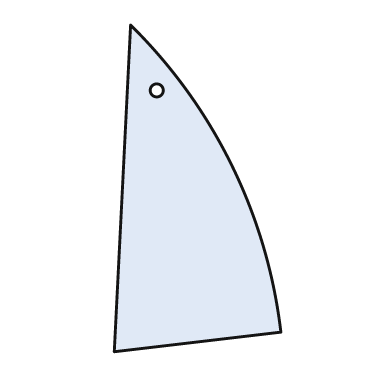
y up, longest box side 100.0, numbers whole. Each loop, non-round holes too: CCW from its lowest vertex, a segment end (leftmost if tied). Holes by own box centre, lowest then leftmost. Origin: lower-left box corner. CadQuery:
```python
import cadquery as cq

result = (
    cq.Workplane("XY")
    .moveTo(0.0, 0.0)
    .lineTo(51.0, 6.0)
    .threePointArc((36.0, 57.0), (5.0, 100.0))
    .close()
    .moveTo(13.0, 80.0)
    .circle(2.0)
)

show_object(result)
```